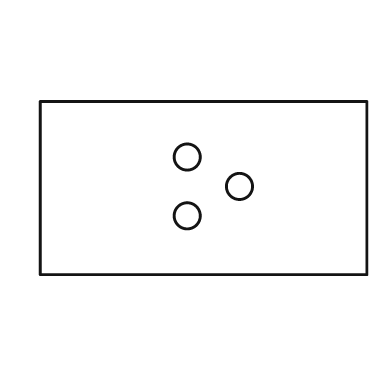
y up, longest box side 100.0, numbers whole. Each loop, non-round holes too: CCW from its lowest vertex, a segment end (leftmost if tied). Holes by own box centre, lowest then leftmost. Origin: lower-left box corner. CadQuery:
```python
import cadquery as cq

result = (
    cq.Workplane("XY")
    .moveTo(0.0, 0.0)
    .lineTo(100.0, 0.0)
    .lineTo(100.0, 53.0)
    .lineTo(0.0, 53.0)
    .close()
    .moveTo(45.0, 18.0)
    .circle(4.0)
    .moveTo(61.0, 27.0)
    .circle(4.0)
    .moveTo(45.0, 36.0)
    .circle(4.0)
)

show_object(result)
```